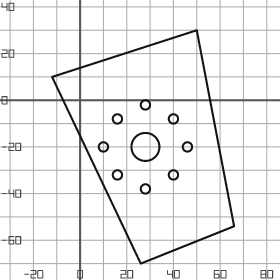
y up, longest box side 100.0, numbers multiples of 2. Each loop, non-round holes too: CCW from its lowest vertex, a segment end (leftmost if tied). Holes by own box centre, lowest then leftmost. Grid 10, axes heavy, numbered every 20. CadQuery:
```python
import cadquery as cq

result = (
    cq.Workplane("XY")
    .moveTo(26.0, -70.0)
    .lineTo(66.0, -54.0)
    .lineTo(50.0, 30.0)
    .lineTo(-12.0, 10.0)
    .close()
    .moveTo(28.0, -38.0)
    .circle(2.0)
    .moveTo(16.0, -32.0)
    .circle(2.0)
    .moveTo(40.0, -32.0)
    .circle(2.0)
    .moveTo(10.0, -20.0)
    .circle(2.0)
    .moveTo(28.0, -20.0)
    .circle(6.0)
    .moveTo(46.0, -20.0)
    .circle(2.0)
    .moveTo(16.0, -8.0)
    .circle(2.0)
    .moveTo(40.0, -8.0)
    .circle(2.0)
    .moveTo(28.0, -2.0)
    .circle(2.0)
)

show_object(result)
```